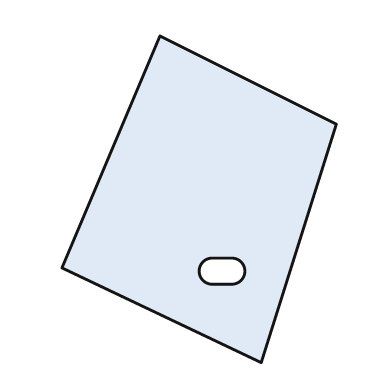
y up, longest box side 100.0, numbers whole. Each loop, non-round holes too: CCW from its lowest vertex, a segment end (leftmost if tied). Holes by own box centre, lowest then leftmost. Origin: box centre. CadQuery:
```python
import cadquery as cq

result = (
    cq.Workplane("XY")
    .moveTo(19.0, -50.0)
    .lineTo(42.0, 23.0)
    .lineTo(-12.0, 50.0)
    .lineTo(-42.0, -21.0)
    .close()
    .moveTo(4.0, -26.0)
    .lineTo(10.0, -26.0)
    .threePointArc((14.0, -22.0), (10.0, -18.0))
    .lineTo(4.0, -18.0)
    .threePointArc((0.0, -22.0), (4.0, -26.0))
    .close()
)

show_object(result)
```